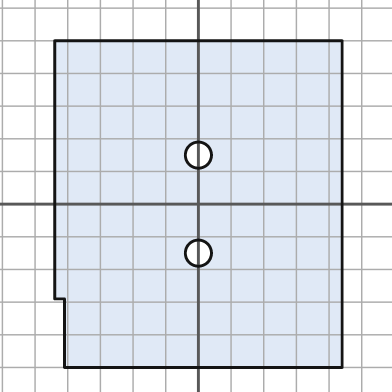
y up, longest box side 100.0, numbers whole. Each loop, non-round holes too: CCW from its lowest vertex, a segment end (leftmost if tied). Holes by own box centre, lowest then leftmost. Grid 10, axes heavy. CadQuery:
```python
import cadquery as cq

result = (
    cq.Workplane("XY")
    .moveTo(-41.0, -50.0)
    .lineTo(44.0, -50.0)
    .lineTo(44.0, 50.0)
    .lineTo(-44.0, 50.0)
    .lineTo(-44.0, -29.0)
    .lineTo(-41.0, -29.0)
    .close()
    .moveTo(0.0, -15.0)
    .circle(4.0)
    .moveTo(0.0, 15.0)
    .circle(4.0)
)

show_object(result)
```